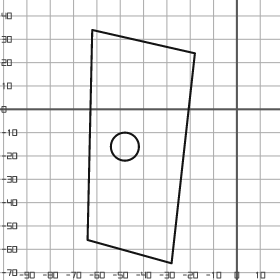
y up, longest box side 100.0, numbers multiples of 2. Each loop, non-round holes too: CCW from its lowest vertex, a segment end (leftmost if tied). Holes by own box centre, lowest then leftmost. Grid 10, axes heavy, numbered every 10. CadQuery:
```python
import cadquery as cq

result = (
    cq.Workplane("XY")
    .moveTo(-28.0, -66.0)
    .lineTo(-18.0, 24.0)
    .lineTo(-62.0, 34.0)
    .lineTo(-64.0, -56.0)
    .close()
    .moveTo(-48.0, -16.0)
    .circle(6.0)
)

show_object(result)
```